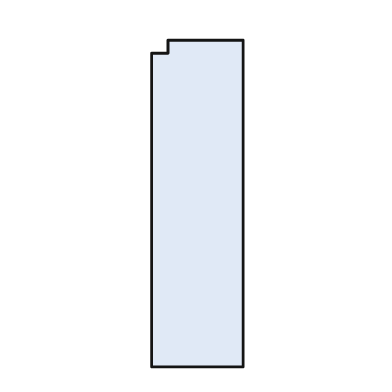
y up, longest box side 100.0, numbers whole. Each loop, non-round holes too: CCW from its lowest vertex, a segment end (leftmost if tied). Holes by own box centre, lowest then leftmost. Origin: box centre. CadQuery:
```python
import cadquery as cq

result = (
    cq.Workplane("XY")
    .moveTo(-14.0, -50.0)
    .lineTo(14.0, -50.0)
    .lineTo(14.0, 50.0)
    .lineTo(-9.0, 50.0)
    .lineTo(-9.0, 46.0)
    .lineTo(-14.0, 46.0)
    .close()
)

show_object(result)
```